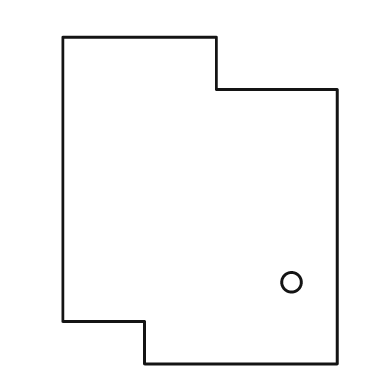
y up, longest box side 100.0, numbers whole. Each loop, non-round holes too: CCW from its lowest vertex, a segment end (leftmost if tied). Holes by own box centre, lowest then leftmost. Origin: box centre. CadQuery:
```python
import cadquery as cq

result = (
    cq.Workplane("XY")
    .moveTo(-17.0, -50.0)
    .lineTo(42.0, -50.0)
    .lineTo(42.0, 34.0)
    .lineTo(5.0, 34.0)
    .lineTo(5.0, 50.0)
    .lineTo(-42.0, 50.0)
    .lineTo(-42.0, -37.0)
    .lineTo(-17.0, -37.0)
    .close()
    .moveTo(28.0, -25.0)
    .circle(3.0)
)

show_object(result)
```